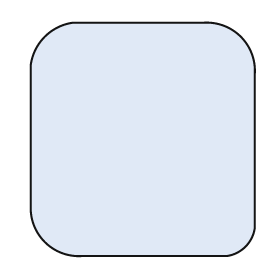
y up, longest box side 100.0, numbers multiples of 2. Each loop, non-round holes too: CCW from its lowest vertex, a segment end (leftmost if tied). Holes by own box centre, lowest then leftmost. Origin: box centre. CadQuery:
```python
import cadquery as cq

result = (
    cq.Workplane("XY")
    .moveTo(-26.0, -50.0)
    .lineTo(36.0, -50.0)
    .threePointArc((44.0, -46.0), (48.0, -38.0))
    .lineTo(48.0, 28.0)
    .threePointArc((42.0, 44.0), (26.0, 50.0))
    .lineTo(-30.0, 50.0)
    .threePointArc((-42.0, 44.0), (-48.0, 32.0))
    .lineTo(-48.0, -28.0)
    .threePointArc((-42.0, -44.0), (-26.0, -50.0))
    .close()
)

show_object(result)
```